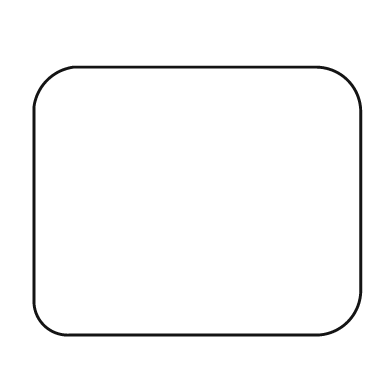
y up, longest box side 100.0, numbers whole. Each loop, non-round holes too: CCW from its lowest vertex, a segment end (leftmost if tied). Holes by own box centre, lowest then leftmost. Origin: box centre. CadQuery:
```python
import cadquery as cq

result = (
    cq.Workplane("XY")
    .moveTo(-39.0, -41.0)
    .lineTo(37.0, -41.0)
    .threePointArc((46.0, -37.0), (50.0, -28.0))
    .lineTo(50.0, 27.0)
    .threePointArc((46.0, 37.0), (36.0, 41.0))
    .lineTo(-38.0, 41.0)
    .threePointArc((-46.0, 37.0), (-50.0, 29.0))
    .lineTo(-50.0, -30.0)
    .threePointArc((-47.0, -38.0), (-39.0, -41.0))
    .close()
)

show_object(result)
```